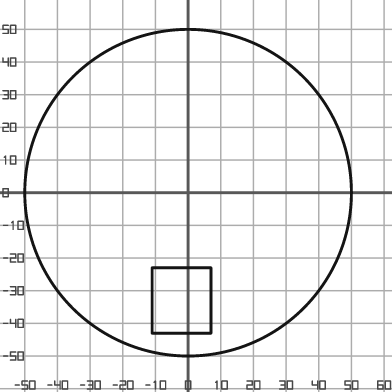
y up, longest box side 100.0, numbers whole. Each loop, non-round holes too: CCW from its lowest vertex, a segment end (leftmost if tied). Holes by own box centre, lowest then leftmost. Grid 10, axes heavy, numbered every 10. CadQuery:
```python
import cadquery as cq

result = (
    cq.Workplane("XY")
    .moveTo(0.0, 0.0)
    .circle(50.0)
    .moveTo(-11.0, -43.0)
    .lineTo(7.0, -43.0)
    .lineTo(7.0, -23.0)
    .lineTo(-11.0, -23.0)
    .close()
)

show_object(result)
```